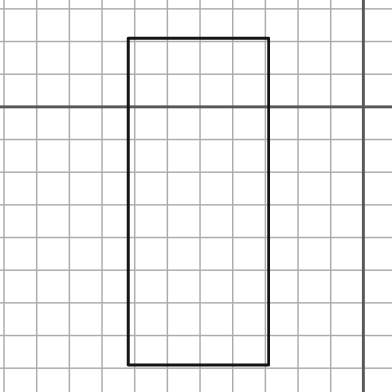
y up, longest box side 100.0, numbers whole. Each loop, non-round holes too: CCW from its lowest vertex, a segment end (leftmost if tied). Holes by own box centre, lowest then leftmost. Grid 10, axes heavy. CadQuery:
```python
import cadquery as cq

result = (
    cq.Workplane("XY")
    .moveTo(-72.0, -79.0)
    .lineTo(-29.0, -79.0)
    .lineTo(-29.0, 21.0)
    .lineTo(-72.0, 21.0)
    .close()
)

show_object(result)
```